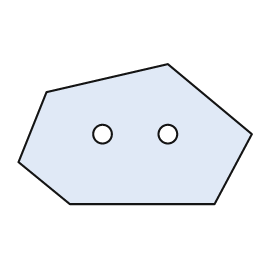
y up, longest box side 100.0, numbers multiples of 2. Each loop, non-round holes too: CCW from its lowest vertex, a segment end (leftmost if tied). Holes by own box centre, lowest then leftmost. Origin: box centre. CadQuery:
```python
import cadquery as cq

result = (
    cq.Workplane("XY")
    .moveTo(-28.0, -30.0)
    .lineTo(34.0, -30.0)
    .lineTo(50.0, 0.0)
    .lineTo(14.0, 30.0)
    .lineTo(-38.0, 18.0)
    .lineTo(-50.0, -12.0)
    .close()
    .moveTo(-14.0, 0.0)
    .circle(4.0)
    .moveTo(14.0, 0.0)
    .circle(4.0)
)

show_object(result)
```